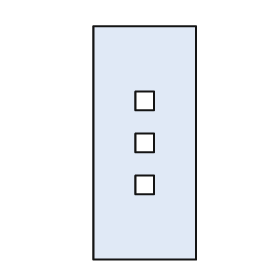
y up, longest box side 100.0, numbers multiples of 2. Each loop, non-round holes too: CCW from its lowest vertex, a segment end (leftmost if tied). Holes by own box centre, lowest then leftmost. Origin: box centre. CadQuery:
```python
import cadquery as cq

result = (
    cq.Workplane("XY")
    .moveTo(-22.0, -50.0)
    .lineTo(22.0, -50.0)
    .lineTo(22.0, 50.0)
    .lineTo(-22.0, 50.0)
    .close()
    .moveTo(-4.0, -22.0)
    .lineTo(4.0, -22.0)
    .lineTo(4.0, -14.0)
    .lineTo(-4.0, -14.0)
    .close()
    .moveTo(-4.0, -4.0)
    .lineTo(4.0, -4.0)
    .lineTo(4.0, 4.0)
    .lineTo(-4.0, 4.0)
    .close()
    .moveTo(-4.0, 14.0)
    .lineTo(4.0, 14.0)
    .lineTo(4.0, 22.0)
    .lineTo(-4.0, 22.0)
    .close()
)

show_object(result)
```